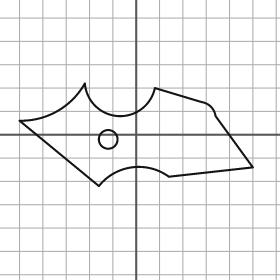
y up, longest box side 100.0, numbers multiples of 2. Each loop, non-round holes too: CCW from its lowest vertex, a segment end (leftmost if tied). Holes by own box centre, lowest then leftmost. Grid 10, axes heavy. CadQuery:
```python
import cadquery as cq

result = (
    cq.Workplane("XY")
    .moveTo(-16.0, -22.0)
    .threePointArc((-2.0, -14.0), (14.0, -18.0))
    .lineTo(50.0, -14.0)
    .lineTo(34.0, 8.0)
    .threePointArc((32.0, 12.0), (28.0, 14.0))
    .lineTo(8.0, 20.0)
    .threePointArc((-8.0, 8.0), (-22.0, 22.0))
    .threePointArc((-34.0, 10.0), (-50.0, 6.0))
    .close()
    .moveTo(-12.0, -2.0)
    .circle(4.0)
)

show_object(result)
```